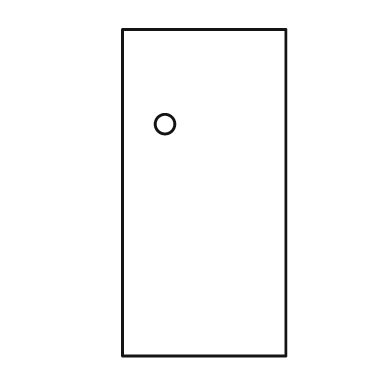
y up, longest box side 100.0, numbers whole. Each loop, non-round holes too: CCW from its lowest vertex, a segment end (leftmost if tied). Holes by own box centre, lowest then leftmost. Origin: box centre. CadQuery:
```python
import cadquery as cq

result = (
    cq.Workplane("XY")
    .moveTo(-25.0, -50.0)
    .lineTo(25.0, -50.0)
    .lineTo(25.0, 50.0)
    .lineTo(-25.0, 50.0)
    .close()
    .moveTo(-12.0, 21.0)
    .circle(3.0)
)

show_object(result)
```